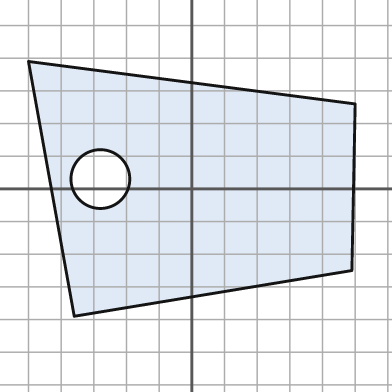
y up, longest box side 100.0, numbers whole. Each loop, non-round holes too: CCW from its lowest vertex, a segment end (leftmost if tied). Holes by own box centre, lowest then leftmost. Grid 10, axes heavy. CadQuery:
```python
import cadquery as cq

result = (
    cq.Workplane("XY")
    .moveTo(-36.0, -39.0)
    .lineTo(49.0, -25.0)
    .lineTo(50.0, 26.0)
    .lineTo(-50.0, 39.0)
    .close()
    .moveTo(-28.0, 3.0)
    .circle(9.0)
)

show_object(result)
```